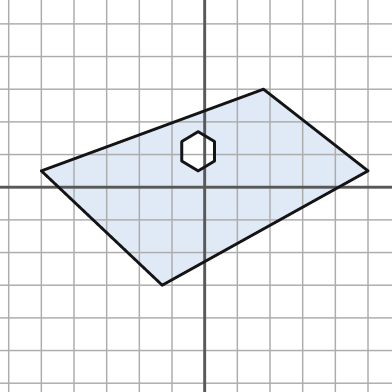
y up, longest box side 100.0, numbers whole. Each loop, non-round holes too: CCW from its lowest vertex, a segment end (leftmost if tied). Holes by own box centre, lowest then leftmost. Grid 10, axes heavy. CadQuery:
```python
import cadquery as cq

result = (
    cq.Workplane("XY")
    .moveTo(-13.0, -30.0)
    .lineTo(50.0, 5.0)
    .lineTo(18.0, 30.0)
    .lineTo(-50.0, 5.0)
    .close()
    .moveTo(-2.0, 5.0)
    .lineTo(3.0, 8.0)
    .lineTo(3.0, 14.0)
    .lineTo(-2.0, 17.0)
    .lineTo(-7.0, 14.0)
    .lineTo(-7.0, 8.0)
    .close()
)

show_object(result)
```